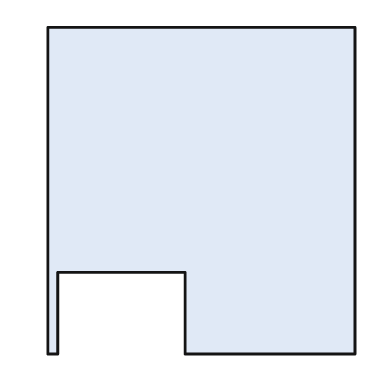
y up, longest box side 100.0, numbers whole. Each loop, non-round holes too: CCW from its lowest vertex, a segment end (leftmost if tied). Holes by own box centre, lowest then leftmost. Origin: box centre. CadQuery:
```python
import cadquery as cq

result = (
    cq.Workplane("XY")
    .moveTo(-47.0, -50.0)
    .lineTo(-44.0, -50.0)
    .lineTo(-44.0, -25.0)
    .lineTo(-5.0, -25.0)
    .lineTo(-5.0, -50.0)
    .lineTo(47.0, -50.0)
    .lineTo(47.0, 50.0)
    .lineTo(-47.0, 50.0)
    .close()
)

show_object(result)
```